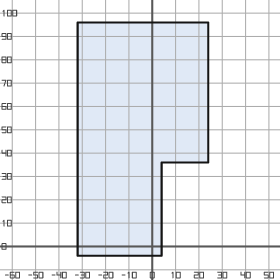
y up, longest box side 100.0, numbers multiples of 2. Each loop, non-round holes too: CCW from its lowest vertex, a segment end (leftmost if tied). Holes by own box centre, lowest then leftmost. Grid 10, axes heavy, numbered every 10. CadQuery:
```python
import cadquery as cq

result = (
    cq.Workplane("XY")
    .moveTo(-32.0, -4.0)
    .lineTo(4.0, -4.0)
    .lineTo(4.0, 36.0)
    .lineTo(24.0, 36.0)
    .lineTo(24.0, 96.0)
    .lineTo(-32.0, 96.0)
    .close()
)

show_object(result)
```